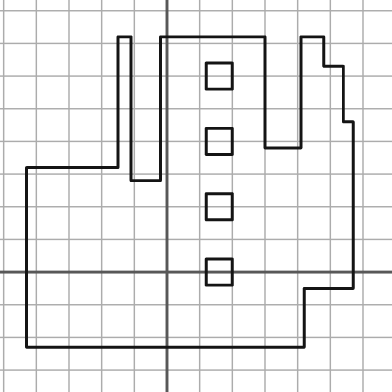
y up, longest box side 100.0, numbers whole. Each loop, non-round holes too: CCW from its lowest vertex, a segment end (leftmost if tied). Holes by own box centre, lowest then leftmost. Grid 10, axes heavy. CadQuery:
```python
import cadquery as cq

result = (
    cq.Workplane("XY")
    .moveTo(-43.0, -23.0)
    .lineTo(42.0, -23.0)
    .lineTo(42.0, -5.0)
    .lineTo(57.0, -5.0)
    .lineTo(57.0, 46.0)
    .lineTo(54.0, 46.0)
    .lineTo(54.0, 63.0)
    .lineTo(48.0, 63.0)
    .lineTo(48.0, 72.0)
    .lineTo(41.0, 72.0)
    .lineTo(41.0, 38.0)
    .lineTo(30.0, 38.0)
    .lineTo(30.0, 72.0)
    .lineTo(-2.0, 72.0)
    .lineTo(-2.0, 28.0)
    .lineTo(-11.0, 28.0)
    .lineTo(-11.0, 72.0)
    .lineTo(-15.0, 72.0)
    .lineTo(-15.0, 32.0)
    .lineTo(-43.0, 32.0)
    .close()
    .moveTo(12.0, -4.0)
    .lineTo(20.0, -4.0)
    .lineTo(20.0, 4.0)
    .lineTo(12.0, 4.0)
    .close()
    .moveTo(12.0, 16.0)
    .lineTo(20.0, 16.0)
    .lineTo(20.0, 24.0)
    .lineTo(12.0, 24.0)
    .close()
    .moveTo(12.0, 36.0)
    .lineTo(20.0, 36.0)
    .lineTo(20.0, 44.0)
    .lineTo(12.0, 44.0)
    .close()
    .moveTo(12.0, 56.0)
    .lineTo(20.0, 56.0)
    .lineTo(20.0, 64.0)
    .lineTo(12.0, 64.0)
    .close()
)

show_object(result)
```